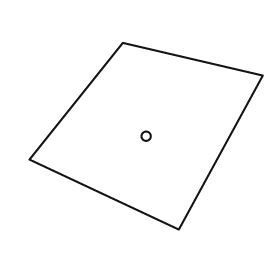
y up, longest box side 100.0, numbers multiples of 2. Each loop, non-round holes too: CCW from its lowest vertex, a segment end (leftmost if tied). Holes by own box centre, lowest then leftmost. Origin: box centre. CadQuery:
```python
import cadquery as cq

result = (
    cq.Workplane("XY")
    .moveTo(14.0, -40.0)
    .lineTo(50.0, 26.0)
    .lineTo(-10.0, 40.0)
    .lineTo(-50.0, -10.0)
    .close()
    .moveTo(0.0, 0.0)
    .circle(2.0)
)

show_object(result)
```